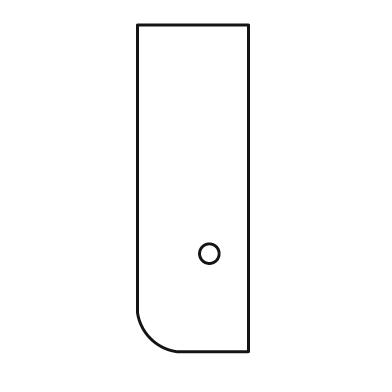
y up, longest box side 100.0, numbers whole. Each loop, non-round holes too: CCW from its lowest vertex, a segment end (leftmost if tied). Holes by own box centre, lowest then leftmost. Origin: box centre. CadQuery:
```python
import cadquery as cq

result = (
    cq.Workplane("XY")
    .moveTo(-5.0, -50.0)
    .lineTo(17.0, -50.0)
    .lineTo(17.0, 50.0)
    .lineTo(-17.0, 50.0)
    .lineTo(-17.0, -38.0)
    .threePointArc((-13.0, -46.0), (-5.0, -50.0))
    .close()
    .moveTo(5.0, -20.0)
    .circle(3.0)
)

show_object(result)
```